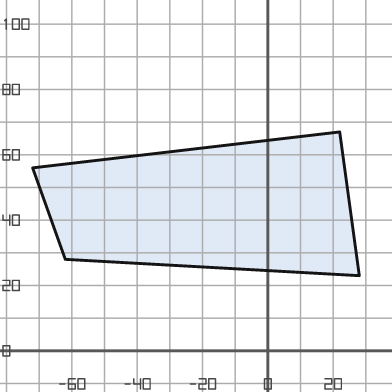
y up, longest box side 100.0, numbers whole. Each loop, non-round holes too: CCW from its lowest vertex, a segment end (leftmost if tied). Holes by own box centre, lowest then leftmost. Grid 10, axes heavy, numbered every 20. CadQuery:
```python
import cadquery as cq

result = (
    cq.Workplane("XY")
    .moveTo(28.0, 23.0)
    .lineTo(22.0, 67.0)
    .lineTo(-72.0, 56.0)
    .lineTo(-62.0, 28.0)
    .close()
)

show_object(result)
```